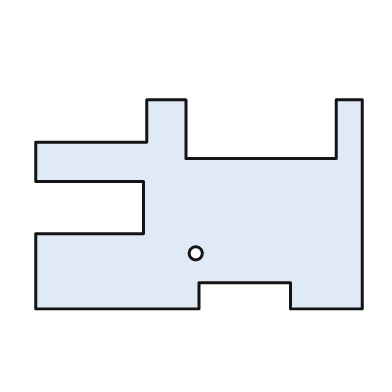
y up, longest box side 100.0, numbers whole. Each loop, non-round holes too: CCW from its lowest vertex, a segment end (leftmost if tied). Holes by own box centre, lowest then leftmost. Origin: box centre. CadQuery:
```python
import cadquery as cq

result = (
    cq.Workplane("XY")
    .moveTo(-50.0, -32.0)
    .lineTo(0.0, -32.0)
    .lineTo(0.0, -24.0)
    .lineTo(28.0, -24.0)
    .lineTo(28.0, -32.0)
    .lineTo(50.0, -32.0)
    .lineTo(50.0, 32.0)
    .lineTo(42.0, 32.0)
    .lineTo(42.0, 14.0)
    .lineTo(-4.0, 14.0)
    .lineTo(-4.0, 32.0)
    .lineTo(-16.0, 32.0)
    .lineTo(-16.0, 19.0)
    .lineTo(-50.0, 19.0)
    .lineTo(-50.0, 7.0)
    .lineTo(-17.0, 7.0)
    .lineTo(-17.0, -9.0)
    .lineTo(-50.0, -9.0)
    .close()
    .moveTo(-1.0, -15.0)
    .circle(2.0)
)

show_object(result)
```